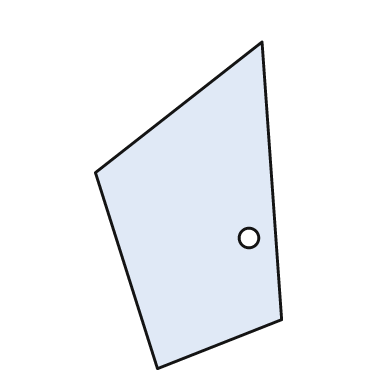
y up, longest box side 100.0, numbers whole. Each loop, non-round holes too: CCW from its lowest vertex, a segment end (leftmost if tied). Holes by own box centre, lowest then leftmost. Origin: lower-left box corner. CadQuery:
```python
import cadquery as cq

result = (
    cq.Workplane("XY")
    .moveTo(19.0, 0.0)
    .lineTo(57.0, 15.0)
    .lineTo(51.0, 100.0)
    .lineTo(0.0, 60.0)
    .close()
    .moveTo(47.0, 40.0)
    .circle(3.0)
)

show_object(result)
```